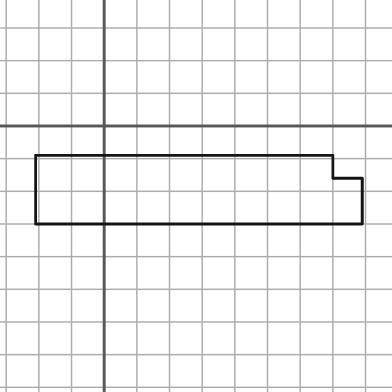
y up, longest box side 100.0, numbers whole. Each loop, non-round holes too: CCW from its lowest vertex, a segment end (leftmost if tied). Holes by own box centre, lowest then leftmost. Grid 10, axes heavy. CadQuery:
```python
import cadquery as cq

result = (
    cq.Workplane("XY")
    .moveTo(-21.0, -30.0)
    .lineTo(79.0, -30.0)
    .lineTo(79.0, -16.0)
    .lineTo(70.0, -16.0)
    .lineTo(70.0, -9.0)
    .lineTo(-21.0, -9.0)
    .close()
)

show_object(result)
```